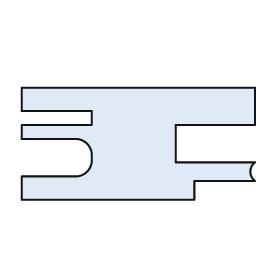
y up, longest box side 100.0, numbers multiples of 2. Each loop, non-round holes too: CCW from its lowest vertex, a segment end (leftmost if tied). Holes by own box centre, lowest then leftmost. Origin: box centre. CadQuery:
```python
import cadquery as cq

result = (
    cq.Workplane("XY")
    .moveTo(-50.0, -24.0)
    .lineTo(24.0, -24.0)
    .lineTo(24.0, -16.0)
    .lineTo(50.0, -16.0)
    .threePointArc((48.0, -12.0), (50.0, -8.0))
    .lineTo(16.0, -8.0)
    .lineTo(16.0, 8.0)
    .lineTo(50.0, 8.0)
    .lineTo(50.0, 24.0)
    .lineTo(-50.0, 24.0)
    .lineTo(-50.0, 14.0)
    .lineTo(-20.0, 14.0)
    .lineTo(-20.0, 8.0)
    .lineTo(-50.0, 8.0)
    .lineTo(-50.0, 2.0)
    .lineTo(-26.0, 2.0)
    .threePointArc((-22.0, 0.0), (-20.0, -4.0))
    .lineTo(-20.0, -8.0)
    .threePointArc((-22.0, -12.0), (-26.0, -14.0))
    .lineTo(-50.0, -14.0)
    .close()
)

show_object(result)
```